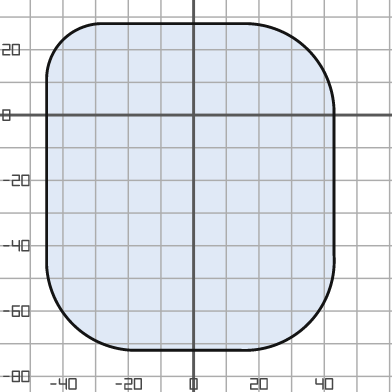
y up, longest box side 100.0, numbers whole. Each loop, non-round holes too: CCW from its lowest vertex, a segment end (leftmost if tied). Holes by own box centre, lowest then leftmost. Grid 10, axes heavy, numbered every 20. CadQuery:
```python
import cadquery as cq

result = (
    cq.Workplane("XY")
    .moveTo(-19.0, -72.0)
    .lineTo(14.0, -72.0)
    .threePointArc((35.0, -64.0), (43.0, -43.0))
    .lineTo(43.0, 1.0)
    .threePointArc((35.0, 20.0), (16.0, 28.0))
    .lineTo(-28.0, 28.0)
    .threePointArc((-40.0, 23.0), (-45.0, 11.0))
    .lineTo(-45.0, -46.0)
    .threePointArc((-37.0, -64.0), (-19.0, -72.0))
    .close()
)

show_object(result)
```